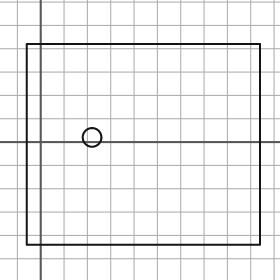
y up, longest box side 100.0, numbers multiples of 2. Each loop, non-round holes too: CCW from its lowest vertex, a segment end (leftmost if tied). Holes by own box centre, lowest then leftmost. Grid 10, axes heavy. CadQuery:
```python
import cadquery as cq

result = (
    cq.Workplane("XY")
    .moveTo(-6.0, -44.0)
    .lineTo(94.0, -44.0)
    .lineTo(94.0, 42.0)
    .lineTo(-6.0, 42.0)
    .close()
    .moveTo(22.0, 2.0)
    .circle(4.0)
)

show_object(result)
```